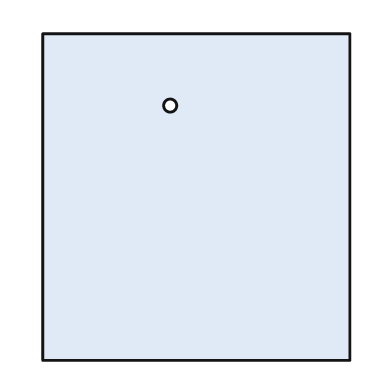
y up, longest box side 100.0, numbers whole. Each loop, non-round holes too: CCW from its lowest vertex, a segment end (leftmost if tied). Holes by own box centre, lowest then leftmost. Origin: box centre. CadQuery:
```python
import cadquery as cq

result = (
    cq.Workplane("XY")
    .moveTo(-47.0, -50.0)
    .lineTo(47.0, -50.0)
    .lineTo(47.0, 50.0)
    .lineTo(-47.0, 50.0)
    .close()
    .moveTo(-8.0, 28.0)
    .circle(2.0)
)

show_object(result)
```